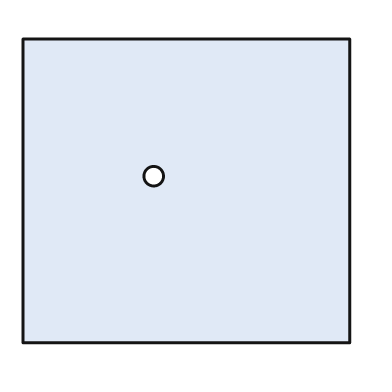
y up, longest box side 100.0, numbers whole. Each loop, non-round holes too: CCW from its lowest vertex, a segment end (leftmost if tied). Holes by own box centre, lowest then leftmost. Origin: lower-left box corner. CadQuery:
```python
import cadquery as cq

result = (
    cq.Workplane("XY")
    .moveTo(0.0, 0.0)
    .lineTo(100.0, 0.0)
    .lineTo(100.0, 93.0)
    .lineTo(0.0, 93.0)
    .close()
    .moveTo(40.0, 51.0)
    .circle(3.0)
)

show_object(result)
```